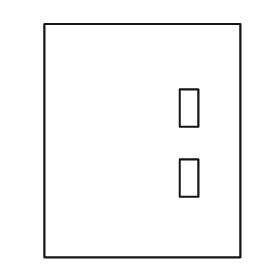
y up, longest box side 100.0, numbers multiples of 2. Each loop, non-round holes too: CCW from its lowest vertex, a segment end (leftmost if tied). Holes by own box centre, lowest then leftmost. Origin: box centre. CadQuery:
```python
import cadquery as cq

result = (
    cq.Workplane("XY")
    .moveTo(-42.0, -50.0)
    .lineTo(42.0, -50.0)
    .lineTo(42.0, 50.0)
    .lineTo(-42.0, 50.0)
    .close()
    .moveTo(16.0, -24.0)
    .lineTo(24.0, -24.0)
    .lineTo(24.0, -8.0)
    .lineTo(16.0, -8.0)
    .close()
    .moveTo(16.0, 6.0)
    .lineTo(24.0, 6.0)
    .lineTo(24.0, 22.0)
    .lineTo(16.0, 22.0)
    .close()
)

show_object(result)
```